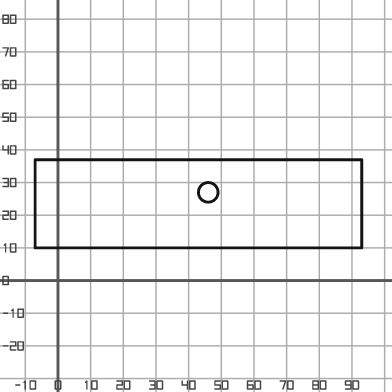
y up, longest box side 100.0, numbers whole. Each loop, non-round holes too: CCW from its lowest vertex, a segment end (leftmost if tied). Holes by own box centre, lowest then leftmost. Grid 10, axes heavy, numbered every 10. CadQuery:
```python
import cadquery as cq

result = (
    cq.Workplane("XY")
    .moveTo(-7.0, 10.0)
    .lineTo(93.0, 10.0)
    .lineTo(93.0, 37.0)
    .lineTo(-7.0, 37.0)
    .close()
    .moveTo(46.0, 27.0)
    .circle(3.0)
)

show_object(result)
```